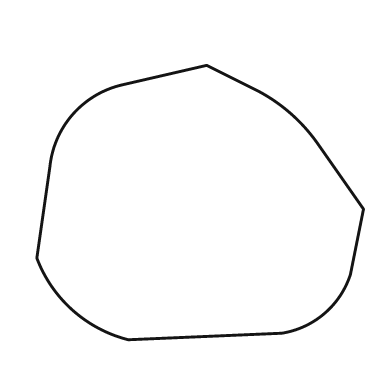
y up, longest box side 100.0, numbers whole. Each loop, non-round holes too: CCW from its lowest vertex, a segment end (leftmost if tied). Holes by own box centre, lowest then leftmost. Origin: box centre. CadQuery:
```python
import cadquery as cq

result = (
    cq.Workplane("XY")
    .moveTo(-22.0, -42.0)
    .lineTo(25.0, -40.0)
    .threePointArc((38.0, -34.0), (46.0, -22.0))
    .lineTo(50.0, -2.0)
    .lineTo(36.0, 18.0)
    .threePointArc((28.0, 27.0), (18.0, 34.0))
    .lineTo(2.0, 42.0)
    .lineTo(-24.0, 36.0)
    .threePointArc((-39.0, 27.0), (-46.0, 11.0))
    .lineTo(-50.0, -17.0)
    .threePointArc((-39.0, -33.0), (-22.0, -42.0))
    .close()
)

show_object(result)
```